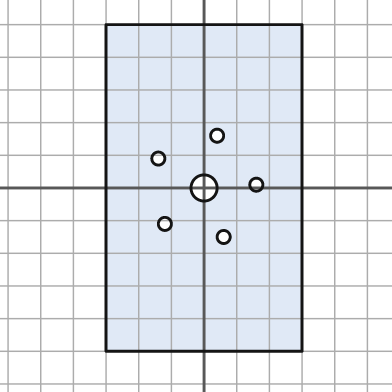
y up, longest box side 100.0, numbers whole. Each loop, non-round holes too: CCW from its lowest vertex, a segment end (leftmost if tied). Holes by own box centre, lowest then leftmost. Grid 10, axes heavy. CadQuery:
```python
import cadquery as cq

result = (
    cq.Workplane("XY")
    .moveTo(-30.0, -50.0)
    .lineTo(30.0, -50.0)
    .lineTo(30.0, 50.0)
    .lineTo(-30.0, 50.0)
    .close()
    .moveTo(6.0, -15.0)
    .circle(2.0)
    .moveTo(-12.0, -11.0)
    .circle(2.0)
    .moveTo(0.0, 0.0)
    .circle(4.0)
    .moveTo(16.0, 1.0)
    .circle(2.0)
    .moveTo(-14.0, 9.0)
    .circle(2.0)
    .moveTo(4.0, 16.0)
    .circle(2.0)
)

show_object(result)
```